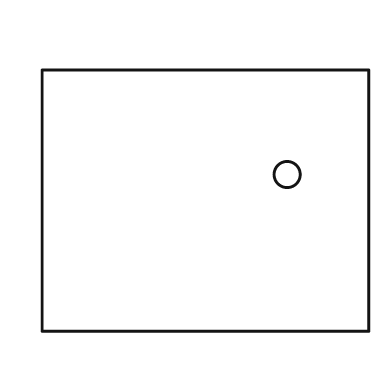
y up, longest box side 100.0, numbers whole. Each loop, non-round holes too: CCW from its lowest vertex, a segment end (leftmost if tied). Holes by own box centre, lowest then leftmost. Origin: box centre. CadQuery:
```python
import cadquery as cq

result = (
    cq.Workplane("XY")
    .moveTo(-50.0, -40.0)
    .lineTo(50.0, -40.0)
    .lineTo(50.0, 40.0)
    .lineTo(-50.0, 40.0)
    .close()
    .moveTo(25.0, 8.0)
    .circle(4.0)
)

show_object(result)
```